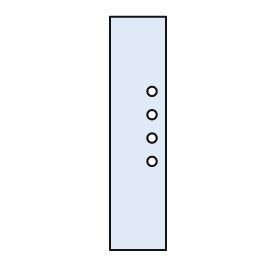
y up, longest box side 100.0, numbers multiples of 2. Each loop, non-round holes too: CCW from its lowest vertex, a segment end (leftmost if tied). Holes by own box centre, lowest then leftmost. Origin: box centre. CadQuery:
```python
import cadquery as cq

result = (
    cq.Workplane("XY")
    .moveTo(-12.0, -50.0)
    .lineTo(12.0, -50.0)
    .lineTo(12.0, 50.0)
    .lineTo(-12.0, 50.0)
    .close()
    .moveTo(6.0, -12.0)
    .circle(2.0)
    .moveTo(6.0, -2.0)
    .circle(2.0)
    .moveTo(6.0, 8.0)
    .circle(2.0)
    .moveTo(6.0, 18.0)
    .circle(2.0)
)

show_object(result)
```